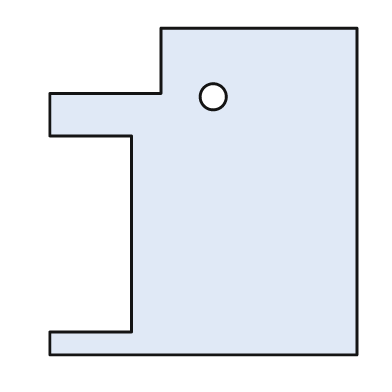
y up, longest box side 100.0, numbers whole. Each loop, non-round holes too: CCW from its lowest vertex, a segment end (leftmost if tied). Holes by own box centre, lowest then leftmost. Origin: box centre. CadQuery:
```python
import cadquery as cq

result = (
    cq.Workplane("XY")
    .moveTo(-47.0, -50.0)
    .lineTo(47.0, -50.0)
    .lineTo(47.0, 50.0)
    .lineTo(-13.0, 50.0)
    .lineTo(-13.0, 30.0)
    .lineTo(-47.0, 30.0)
    .lineTo(-47.0, 17.0)
    .lineTo(-22.0, 17.0)
    .lineTo(-22.0, -43.0)
    .lineTo(-47.0, -43.0)
    .close()
    .moveTo(3.0, 29.0)
    .circle(4.0)
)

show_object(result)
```